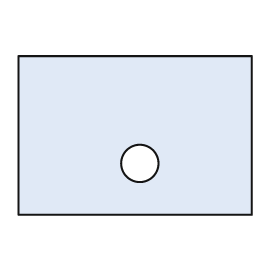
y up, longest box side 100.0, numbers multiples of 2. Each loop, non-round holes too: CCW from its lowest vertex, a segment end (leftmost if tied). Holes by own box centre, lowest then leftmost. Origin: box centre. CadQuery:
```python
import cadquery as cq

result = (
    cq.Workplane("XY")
    .moveTo(-50.0, -34.0)
    .lineTo(50.0, -34.0)
    .lineTo(50.0, 34.0)
    .lineTo(-50.0, 34.0)
    .close()
    .moveTo(2.0, -12.0)
    .circle(8.0)
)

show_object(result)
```